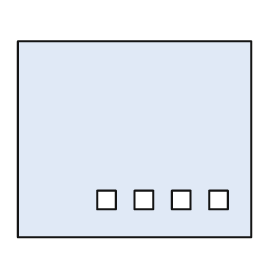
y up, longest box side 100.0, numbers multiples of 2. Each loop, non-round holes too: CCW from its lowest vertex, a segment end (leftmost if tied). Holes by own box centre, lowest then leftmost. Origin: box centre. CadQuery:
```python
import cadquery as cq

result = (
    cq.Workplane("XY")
    .moveTo(-50.0, -42.0)
    .lineTo(50.0, -42.0)
    .lineTo(50.0, 42.0)
    .lineTo(-50.0, 42.0)
    .close()
    .moveTo(-16.0, -30.0)
    .lineTo(-8.0, -30.0)
    .lineTo(-8.0, -22.0)
    .lineTo(-16.0, -22.0)
    .close()
    .moveTo(0.0, -30.0)
    .lineTo(8.0, -30.0)
    .lineTo(8.0, -22.0)
    .lineTo(0.0, -22.0)
    .close()
    .moveTo(16.0, -30.0)
    .lineTo(24.0, -30.0)
    .lineTo(24.0, -22.0)
    .lineTo(16.0, -22.0)
    .close()
    .moveTo(32.0, -30.0)
    .lineTo(40.0, -30.0)
    .lineTo(40.0, -22.0)
    .lineTo(32.0, -22.0)
    .close()
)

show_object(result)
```